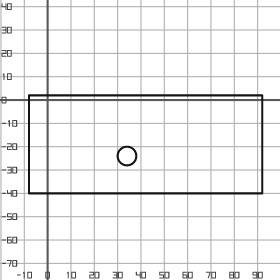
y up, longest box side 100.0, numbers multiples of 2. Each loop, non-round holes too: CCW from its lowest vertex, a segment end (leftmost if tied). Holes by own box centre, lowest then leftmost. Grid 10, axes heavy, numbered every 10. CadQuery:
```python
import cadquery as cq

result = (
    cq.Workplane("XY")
    .moveTo(-8.0, -40.0)
    .lineTo(92.0, -40.0)
    .lineTo(92.0, 2.0)
    .lineTo(-8.0, 2.0)
    .close()
    .moveTo(34.0, -24.0)
    .circle(4.0)
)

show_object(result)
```